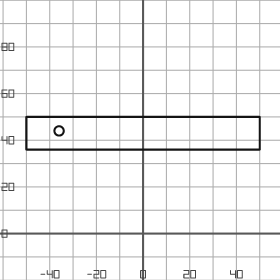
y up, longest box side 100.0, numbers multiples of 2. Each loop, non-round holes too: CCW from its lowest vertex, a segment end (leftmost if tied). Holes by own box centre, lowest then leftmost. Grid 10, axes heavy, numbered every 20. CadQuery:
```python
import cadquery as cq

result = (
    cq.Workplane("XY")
    .moveTo(-50.0, 36.0)
    .lineTo(50.0, 36.0)
    .lineTo(50.0, 50.0)
    .lineTo(-50.0, 50.0)
    .close()
    .moveTo(-36.0, 44.0)
    .circle(2.0)
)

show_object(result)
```